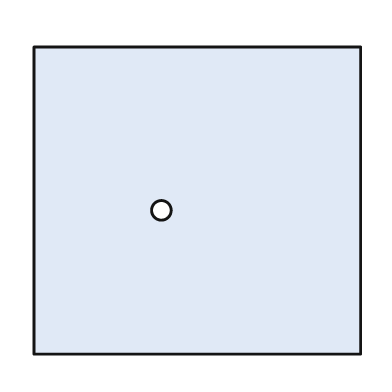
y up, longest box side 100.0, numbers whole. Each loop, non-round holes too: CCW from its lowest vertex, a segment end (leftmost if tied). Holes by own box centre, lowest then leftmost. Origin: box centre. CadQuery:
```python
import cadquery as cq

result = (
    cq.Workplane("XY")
    .moveTo(-50.0, -47.0)
    .lineTo(50.0, -47.0)
    .lineTo(50.0, 47.0)
    .lineTo(-50.0, 47.0)
    .close()
    .moveTo(-11.0, -3.0)
    .circle(3.0)
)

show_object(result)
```